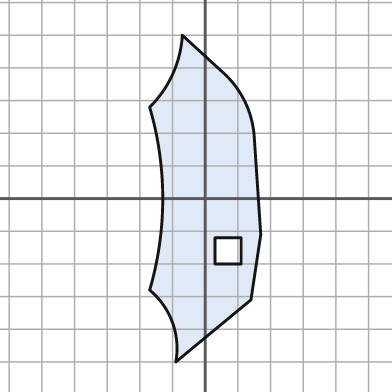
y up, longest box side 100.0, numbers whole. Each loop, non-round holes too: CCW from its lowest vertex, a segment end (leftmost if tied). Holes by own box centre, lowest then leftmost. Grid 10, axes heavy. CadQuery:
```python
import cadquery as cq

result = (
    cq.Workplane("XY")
    .moveTo(-9.0, -50.0)
    .lineTo(14.0, -31.0)
    .lineTo(17.0, -11.0)
    .lineTo(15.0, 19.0)
    .threePointArc((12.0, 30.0), (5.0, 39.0))
    .lineTo(-7.0, 50.0)
    .threePointArc((-10.0, 38.0), (-17.0, 28.0))
    .threePointArc((-13.0, 0.0), (-17.0, -28.0))
    .threePointArc((-10.0, -38.0), (-9.0, -50.0))
    .close()
    .moveTo(3.0, -20.0)
    .lineTo(11.0, -20.0)
    .lineTo(11.0, -12.0)
    .lineTo(3.0, -12.0)
    .close()
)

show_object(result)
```